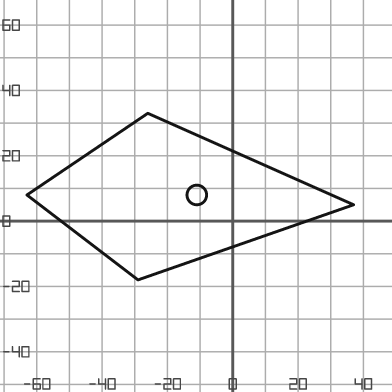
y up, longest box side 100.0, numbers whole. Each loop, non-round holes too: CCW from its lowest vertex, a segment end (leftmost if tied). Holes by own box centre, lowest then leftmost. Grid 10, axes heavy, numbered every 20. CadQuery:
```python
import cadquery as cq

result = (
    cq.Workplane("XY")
    .moveTo(-29.0, -18.0)
    .lineTo(37.0, 5.0)
    .lineTo(-26.0, 33.0)
    .lineTo(-63.0, 8.0)
    .close()
    .moveTo(-11.0, 8.0)
    .circle(3.0)
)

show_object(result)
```